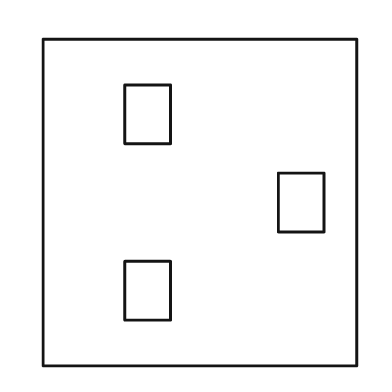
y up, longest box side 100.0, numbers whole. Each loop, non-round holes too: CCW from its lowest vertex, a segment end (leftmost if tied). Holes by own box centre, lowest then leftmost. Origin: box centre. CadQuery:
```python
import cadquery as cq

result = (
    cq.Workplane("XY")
    .moveTo(-48.0, -50.0)
    .lineTo(48.0, -50.0)
    .lineTo(48.0, 50.0)
    .lineTo(-48.0, 50.0)
    .close()
    .moveTo(-23.0, -36.0)
    .lineTo(-9.0, -36.0)
    .lineTo(-9.0, -18.0)
    .lineTo(-23.0, -18.0)
    .close()
    .moveTo(24.0, -9.0)
    .lineTo(38.0, -9.0)
    .lineTo(38.0, 9.0)
    .lineTo(24.0, 9.0)
    .close()
    .moveTo(-23.0, 18.0)
    .lineTo(-9.0, 18.0)
    .lineTo(-9.0, 36.0)
    .lineTo(-23.0, 36.0)
    .close()
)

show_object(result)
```